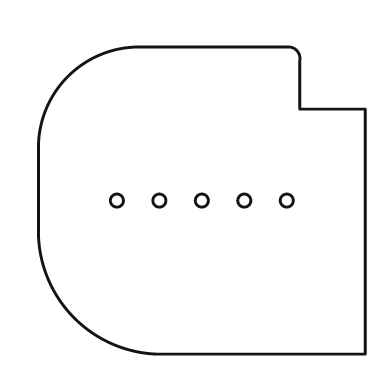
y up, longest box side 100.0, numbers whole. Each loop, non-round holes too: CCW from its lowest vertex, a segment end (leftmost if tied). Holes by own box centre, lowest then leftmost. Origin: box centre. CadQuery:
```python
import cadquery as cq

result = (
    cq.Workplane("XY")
    .moveTo(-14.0, -47.0)
    .lineTo(50.0, -47.0)
    .lineTo(50.0, 28.0)
    .lineTo(30.0, 28.0)
    .lineTo(30.0, 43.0)
    .threePointArc((29.0, 46.0), (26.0, 47.0))
    .lineTo(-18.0, 47.0)
    .threePointArc((-41.0, 38.0), (-50.0, 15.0))
    .lineTo(-50.0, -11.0)
    .threePointArc((-39.0, -36.0), (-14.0, -47.0))
    .close()
    .moveTo(-26.0, 0.0)
    .circle(2.0)
    .moveTo(-13.0, 0.0)
    .circle(2.0)
    .moveTo(0.0, 0.0)
    .circle(2.0)
    .moveTo(13.0, 0.0)
    .circle(2.0)
    .moveTo(26.0, 0.0)
    .circle(2.0)
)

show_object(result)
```